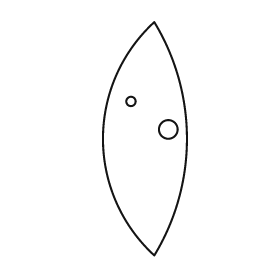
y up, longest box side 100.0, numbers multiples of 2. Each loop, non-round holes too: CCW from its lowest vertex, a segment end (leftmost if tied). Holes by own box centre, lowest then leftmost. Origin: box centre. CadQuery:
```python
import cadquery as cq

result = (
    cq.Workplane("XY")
    .moveTo(4.0, -50.0)
    .threePointArc((18.0, 0.0), (4.0, 50.0))
    .threePointArc((-18.0, 0.0), (4.0, -50.0))
    .close()
    .moveTo(10.0, 4.0)
    .circle(4.0)
    .moveTo(-6.0, 16.0)
    .circle(2.0)
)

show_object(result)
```